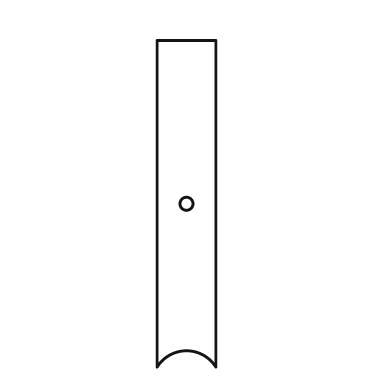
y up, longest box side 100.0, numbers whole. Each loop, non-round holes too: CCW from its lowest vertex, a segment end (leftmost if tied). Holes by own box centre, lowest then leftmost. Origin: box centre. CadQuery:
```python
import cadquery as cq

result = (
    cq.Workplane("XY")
    .moveTo(-9.0, -50.0)
    .threePointArc((0.0, -45.0), (9.0, -50.0))
    .lineTo(9.0, 50.0)
    .lineTo(-9.0, 50.0)
    .close()
    .moveTo(0.0, 0.0)
    .circle(2.0)
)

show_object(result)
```